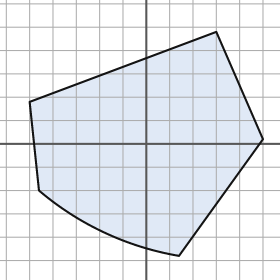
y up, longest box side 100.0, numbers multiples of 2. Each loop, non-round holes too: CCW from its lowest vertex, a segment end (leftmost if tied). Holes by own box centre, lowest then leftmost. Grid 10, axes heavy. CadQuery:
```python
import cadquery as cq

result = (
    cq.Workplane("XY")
    .moveTo(14.0, -48.0)
    .lineTo(50.0, 2.0)
    .lineTo(30.0, 48.0)
    .lineTo(-50.0, 18.0)
    .lineTo(-46.0, -20.0)
    .threePointArc((-18.0, -38.0), (14.0, -48.0))
    .close()
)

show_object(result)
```